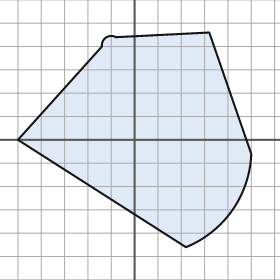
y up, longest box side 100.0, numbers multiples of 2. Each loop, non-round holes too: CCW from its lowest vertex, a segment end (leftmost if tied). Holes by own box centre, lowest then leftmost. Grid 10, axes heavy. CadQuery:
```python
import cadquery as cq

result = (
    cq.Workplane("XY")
    .moveTo(22.0, -46.0)
    .threePointArc((42.0, -30.0), (50.0, -6.0))
    .lineTo(32.0, 46.0)
    .lineTo(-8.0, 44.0)
    .threePointArc((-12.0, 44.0), (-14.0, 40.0))
    .lineTo(-50.0, 0.0)
    .close()
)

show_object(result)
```